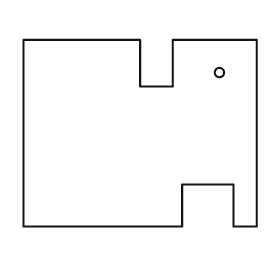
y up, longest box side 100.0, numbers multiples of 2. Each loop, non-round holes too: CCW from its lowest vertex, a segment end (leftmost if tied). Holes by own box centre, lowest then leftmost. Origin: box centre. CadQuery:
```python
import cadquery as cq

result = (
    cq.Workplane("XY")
    .moveTo(-50.0, -40.0)
    .lineTo(18.0, -40.0)
    .lineTo(18.0, -22.0)
    .lineTo(40.0, -22.0)
    .lineTo(40.0, -40.0)
    .lineTo(50.0, -40.0)
    .lineTo(50.0, 40.0)
    .lineTo(14.0, 40.0)
    .lineTo(14.0, 20.0)
    .lineTo(0.0, 20.0)
    .lineTo(0.0, 40.0)
    .lineTo(-50.0, 40.0)
    .close()
    .moveTo(34.0, 26.0)
    .circle(2.0)
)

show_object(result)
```